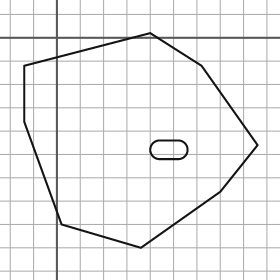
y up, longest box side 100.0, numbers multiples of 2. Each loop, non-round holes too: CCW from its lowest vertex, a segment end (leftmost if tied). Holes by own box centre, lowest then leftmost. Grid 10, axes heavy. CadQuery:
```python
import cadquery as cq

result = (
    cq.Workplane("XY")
    .moveTo(36.0, -90.0)
    .lineTo(70.0, -66.0)
    .lineTo(86.0, -46.0)
    .lineTo(62.0, -12.0)
    .lineTo(40.0, 2.0)
    .lineTo(-14.0, -12.0)
    .lineTo(-14.0, -36.0)
    .lineTo(2.0, -80.0)
    .close()
    .moveTo(44.0, -52.0)
    .lineTo(52.0, -52.0)
    .threePointArc((56.0, -48.0), (52.0, -44.0))
    .lineTo(44.0, -44.0)
    .threePointArc((40.0, -48.0), (44.0, -52.0))
    .close()
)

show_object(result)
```